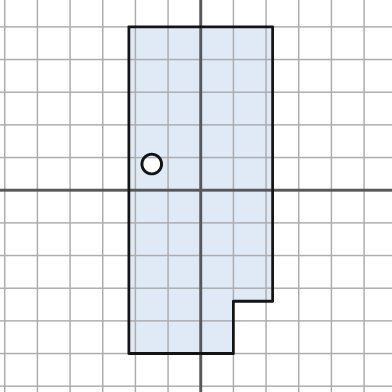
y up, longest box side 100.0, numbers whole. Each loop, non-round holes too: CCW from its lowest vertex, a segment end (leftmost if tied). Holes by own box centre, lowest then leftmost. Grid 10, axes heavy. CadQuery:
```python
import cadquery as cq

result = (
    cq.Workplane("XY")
    .moveTo(-22.0, -50.0)
    .lineTo(10.0, -50.0)
    .lineTo(10.0, -34.0)
    .lineTo(22.0, -34.0)
    .lineTo(22.0, 50.0)
    .lineTo(-22.0, 50.0)
    .close()
    .moveTo(-15.0, 8.0)
    .circle(3.0)
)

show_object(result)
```